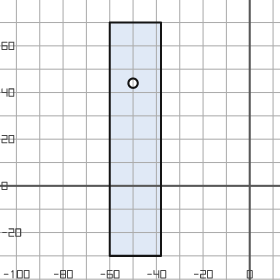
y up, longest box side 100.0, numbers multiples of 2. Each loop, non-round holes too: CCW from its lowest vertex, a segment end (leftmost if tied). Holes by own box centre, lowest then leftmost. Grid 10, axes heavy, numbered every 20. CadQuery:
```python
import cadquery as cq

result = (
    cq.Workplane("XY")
    .moveTo(-60.0, -30.0)
    .lineTo(-38.0, -30.0)
    .lineTo(-38.0, 70.0)
    .lineTo(-60.0, 70.0)
    .close()
    .moveTo(-50.0, 44.0)
    .circle(2.0)
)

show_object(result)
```